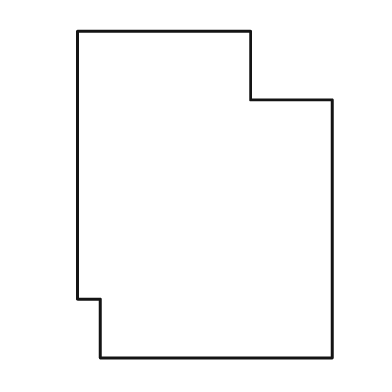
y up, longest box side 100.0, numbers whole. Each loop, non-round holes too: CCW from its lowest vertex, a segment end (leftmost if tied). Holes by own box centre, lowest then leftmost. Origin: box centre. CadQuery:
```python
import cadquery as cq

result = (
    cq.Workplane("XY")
    .moveTo(-32.0, -50.0)
    .lineTo(39.0, -50.0)
    .lineTo(39.0, 29.0)
    .lineTo(14.0, 29.0)
    .lineTo(14.0, 50.0)
    .lineTo(-39.0, 50.0)
    .lineTo(-39.0, -32.0)
    .lineTo(-32.0, -32.0)
    .close()
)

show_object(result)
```